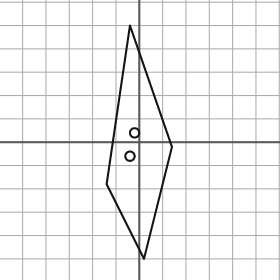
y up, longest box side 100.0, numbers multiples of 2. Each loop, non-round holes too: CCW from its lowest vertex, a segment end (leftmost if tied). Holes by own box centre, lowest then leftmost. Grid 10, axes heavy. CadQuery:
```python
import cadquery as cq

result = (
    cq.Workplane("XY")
    .moveTo(2.0, -50.0)
    .lineTo(14.0, -2.0)
    .lineTo(-4.0, 50.0)
    .lineTo(-14.0, -18.0)
    .close()
    .moveTo(-4.0, -6.0)
    .circle(2.0)
    .moveTo(-2.0, 4.0)
    .circle(2.0)
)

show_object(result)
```